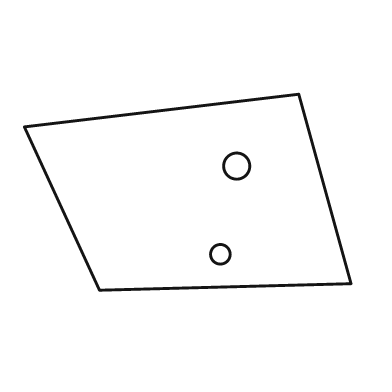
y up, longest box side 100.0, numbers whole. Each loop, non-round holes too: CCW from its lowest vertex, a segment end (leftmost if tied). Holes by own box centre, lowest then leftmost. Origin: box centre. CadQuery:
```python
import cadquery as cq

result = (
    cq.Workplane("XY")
    .moveTo(-27.0, -30.0)
    .lineTo(50.0, -28.0)
    .lineTo(34.0, 30.0)
    .lineTo(-50.0, 20.0)
    .close()
    .moveTo(10.0, -19.0)
    .circle(3.0)
    .moveTo(15.0, 8.0)
    .circle(4.0)
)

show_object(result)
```